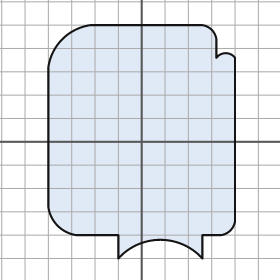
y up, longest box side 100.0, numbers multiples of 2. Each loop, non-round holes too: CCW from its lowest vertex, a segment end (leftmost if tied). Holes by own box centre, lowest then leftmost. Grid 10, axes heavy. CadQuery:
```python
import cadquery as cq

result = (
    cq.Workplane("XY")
    .moveTo(-10.0, -50.0)
    .threePointArc((8.0, -42.0), (26.0, -50.0))
    .lineTo(26.0, -40.0)
    .lineTo(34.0, -40.0)
    .threePointArc((38.0, -38.0), (40.0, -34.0))
    .lineTo(40.0, 36.0)
    .threePointArc((36.0, 38.0), (32.0, 36.0))
    .lineTo(32.0, 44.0)
    .threePointArc((30.0, 48.0), (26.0, 50.0))
    .lineTo(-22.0, 50.0)
    .threePointArc((-34.0, 44.0), (-40.0, 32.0))
    .lineTo(-40.0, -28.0)
    .threePointArc((-36.0, -36.0), (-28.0, -40.0))
    .lineTo(-10.0, -40.0)
    .close()
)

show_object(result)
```